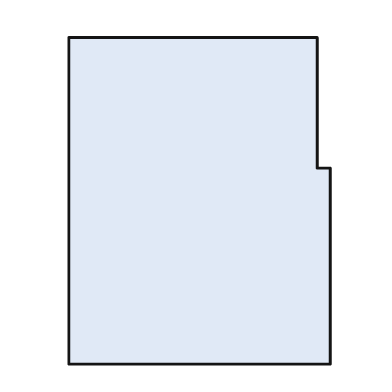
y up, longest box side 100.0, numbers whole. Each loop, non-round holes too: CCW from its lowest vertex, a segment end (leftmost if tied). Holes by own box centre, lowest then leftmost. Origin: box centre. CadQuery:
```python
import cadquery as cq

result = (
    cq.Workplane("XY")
    .moveTo(-40.0, -50.0)
    .lineTo(40.0, -50.0)
    .lineTo(40.0, 10.0)
    .lineTo(36.0, 10.0)
    .lineTo(36.0, 50.0)
    .lineTo(-40.0, 50.0)
    .close()
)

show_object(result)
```